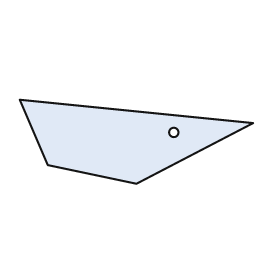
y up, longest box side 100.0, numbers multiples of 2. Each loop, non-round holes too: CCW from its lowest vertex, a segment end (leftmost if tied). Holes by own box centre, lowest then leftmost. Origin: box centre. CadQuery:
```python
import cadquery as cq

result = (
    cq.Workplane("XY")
    .moveTo(0.0, -18.0)
    .lineTo(50.0, 8.0)
    .lineTo(-50.0, 18.0)
    .lineTo(-38.0, -10.0)
    .close()
    .moveTo(16.0, 4.0)
    .circle(2.0)
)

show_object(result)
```